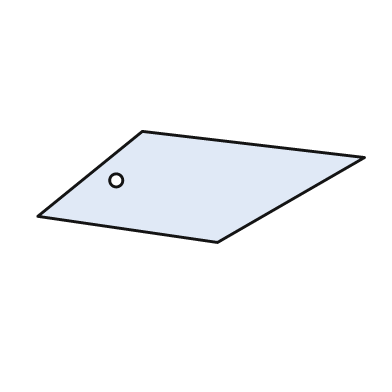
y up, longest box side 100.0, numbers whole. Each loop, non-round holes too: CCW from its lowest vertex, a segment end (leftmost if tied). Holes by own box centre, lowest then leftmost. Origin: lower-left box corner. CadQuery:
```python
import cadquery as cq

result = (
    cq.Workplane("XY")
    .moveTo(55.0, 0.0)
    .lineTo(100.0, 26.0)
    .lineTo(32.0, 34.0)
    .lineTo(0.0, 8.0)
    .close()
    .moveTo(24.0, 19.0)
    .circle(2.0)
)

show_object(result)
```